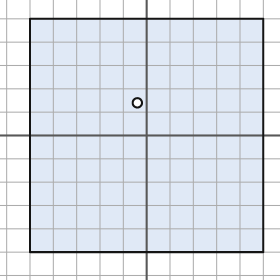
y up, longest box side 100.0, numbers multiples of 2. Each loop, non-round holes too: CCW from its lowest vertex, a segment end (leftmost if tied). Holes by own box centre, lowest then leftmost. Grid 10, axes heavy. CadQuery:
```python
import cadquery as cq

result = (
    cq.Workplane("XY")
    .moveTo(-50.0, -50.0)
    .lineTo(50.0, -50.0)
    .lineTo(50.0, 50.0)
    .lineTo(-50.0, 50.0)
    .close()
    .moveTo(-4.0, 14.0)
    .circle(2.0)
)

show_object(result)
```